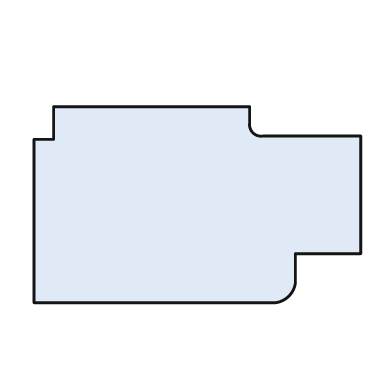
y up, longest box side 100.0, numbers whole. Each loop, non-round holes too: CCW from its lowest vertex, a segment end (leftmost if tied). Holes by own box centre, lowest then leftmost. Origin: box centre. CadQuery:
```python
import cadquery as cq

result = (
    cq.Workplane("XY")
    .moveTo(-50.0, -30.0)
    .lineTo(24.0, -30.0)
    .threePointArc((28.0, -28.0), (30.0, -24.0))
    .lineTo(30.0, -15.0)
    .lineTo(50.0, -15.0)
    .lineTo(50.0, 21.0)
    .lineTo(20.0, 21.0)
    .threePointArc((17.0, 22.0), (16.0, 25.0))
    .lineTo(16.0, 30.0)
    .lineTo(-44.0, 30.0)
    .lineTo(-44.0, 20.0)
    .lineTo(-50.0, 20.0)
    .close()
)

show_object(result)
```